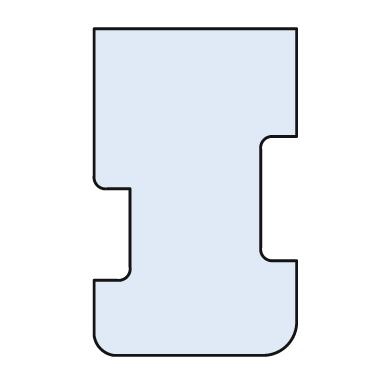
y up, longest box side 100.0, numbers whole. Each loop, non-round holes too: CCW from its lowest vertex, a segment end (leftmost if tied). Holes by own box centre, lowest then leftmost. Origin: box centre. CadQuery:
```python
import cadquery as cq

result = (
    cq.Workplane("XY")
    .moveTo(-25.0, -50.0)
    .lineTo(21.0, -50.0)
    .threePointArc((28.0, -47.0), (31.0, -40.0))
    .lineTo(31.0, -21.0)
    .lineTo(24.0, -21.0)
    .threePointArc((21.0, -20.0), (20.0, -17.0))
    .lineTo(20.0, 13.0)
    .threePointArc((21.0, 16.0), (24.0, 17.0))
    .lineTo(31.0, 17.0)
    .lineTo(31.0, 50.0)
    .lineTo(-31.0, 50.0)
    .lineTo(-31.0, 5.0)
    .threePointArc((-30.0, 2.0), (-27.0, 1.0))
    .lineTo(-20.0, 1.0)
    .lineTo(-20.0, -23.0)
    .threePointArc((-21.0, -26.0), (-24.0, -27.0))
    .lineTo(-31.0, -27.0)
    .lineTo(-31.0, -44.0)
    .threePointArc((-29.0, -48.0), (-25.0, -50.0))
    .close()
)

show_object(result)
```